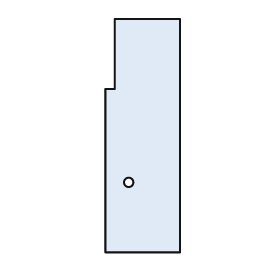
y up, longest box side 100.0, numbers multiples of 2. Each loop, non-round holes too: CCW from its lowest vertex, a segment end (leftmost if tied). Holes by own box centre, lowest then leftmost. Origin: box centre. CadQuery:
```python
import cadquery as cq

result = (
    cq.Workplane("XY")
    .moveTo(-16.0, -50.0)
    .lineTo(16.0, -50.0)
    .lineTo(16.0, 50.0)
    .lineTo(-12.0, 50.0)
    .lineTo(-12.0, 20.0)
    .lineTo(-16.0, 20.0)
    .close()
    .moveTo(-6.0, -20.0)
    .circle(2.0)
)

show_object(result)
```